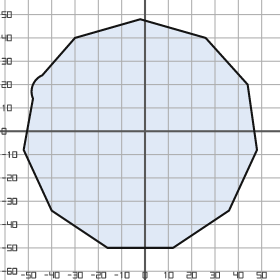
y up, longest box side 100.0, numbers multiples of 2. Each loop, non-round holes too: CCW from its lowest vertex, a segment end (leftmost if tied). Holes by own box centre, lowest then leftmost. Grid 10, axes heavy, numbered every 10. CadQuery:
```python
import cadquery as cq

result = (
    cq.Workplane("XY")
    .moveTo(-16.0, -50.0)
    .lineTo(12.0, -50.0)
    .lineTo(36.0, -34.0)
    .lineTo(48.0, -8.0)
    .lineTo(44.0, 20.0)
    .lineTo(26.0, 40.0)
    .lineTo(-2.0, 48.0)
    .lineTo(-30.0, 40.0)
    .lineTo(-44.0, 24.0)
    .threePointArc((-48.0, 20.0), (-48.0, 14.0))
    .lineTo(-52.0, -8.0)
    .lineTo(-40.0, -34.0)
    .close()
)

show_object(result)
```